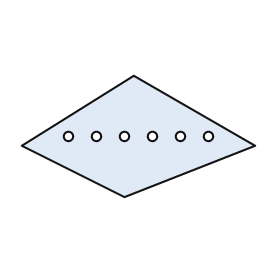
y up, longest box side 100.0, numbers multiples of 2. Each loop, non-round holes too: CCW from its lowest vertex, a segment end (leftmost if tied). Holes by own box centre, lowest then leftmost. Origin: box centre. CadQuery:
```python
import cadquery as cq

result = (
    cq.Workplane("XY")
    .moveTo(-6.0, -26.0)
    .lineTo(50.0, -4.0)
    .lineTo(-2.0, 26.0)
    .lineTo(-50.0, -4.0)
    .close()
    .moveTo(-30.0, 0.0)
    .circle(2.0)
    .moveTo(-18.0, 0.0)
    .circle(2.0)
    .moveTo(-6.0, 0.0)
    .circle(2.0)
    .moveTo(6.0, 0.0)
    .circle(2.0)
    .moveTo(18.0, 0.0)
    .circle(2.0)
    .moveTo(30.0, 0.0)
    .circle(2.0)
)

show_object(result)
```